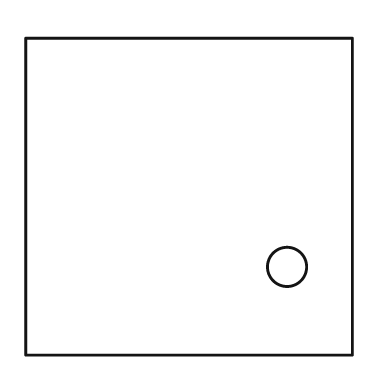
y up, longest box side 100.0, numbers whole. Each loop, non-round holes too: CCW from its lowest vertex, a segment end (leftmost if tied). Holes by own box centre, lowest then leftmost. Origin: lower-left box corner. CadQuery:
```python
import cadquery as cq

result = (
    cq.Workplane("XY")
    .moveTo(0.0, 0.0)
    .lineTo(100.0, 0.0)
    .lineTo(100.0, 97.0)
    .lineTo(0.0, 97.0)
    .close()
    .moveTo(80.0, 27.0)
    .circle(6.0)
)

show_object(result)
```